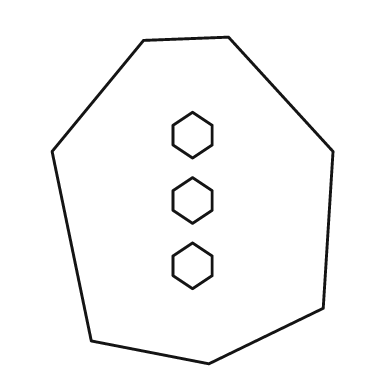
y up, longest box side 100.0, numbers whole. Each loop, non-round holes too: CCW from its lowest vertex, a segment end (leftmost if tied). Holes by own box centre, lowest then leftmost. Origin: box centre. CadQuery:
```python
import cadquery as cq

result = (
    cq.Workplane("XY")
    .moveTo(5.0, -50.0)
    .lineTo(40.0, -33.0)
    .lineTo(43.0, 15.0)
    .lineTo(11.0, 50.0)
    .lineTo(-15.0, 49.0)
    .lineTo(-43.0, 15.0)
    .lineTo(-31.0, -43.0)
    .close()
    .moveTo(0.0, -27.0)
    .lineTo(6.0, -23.0)
    .lineTo(6.0, -17.0)
    .lineTo(0.0, -13.0)
    .lineTo(-6.0, -17.0)
    .lineTo(-6.0, -23.0)
    .close()
    .moveTo(0.0, -7.0)
    .lineTo(6.0, -3.0)
    .lineTo(6.0, 3.0)
    .lineTo(0.0, 7.0)
    .lineTo(-6.0, 3.0)
    .lineTo(-6.0, -3.0)
    .close()
    .moveTo(0.0, 13.0)
    .lineTo(6.0, 17.0)
    .lineTo(6.0, 23.0)
    .lineTo(0.0, 27.0)
    .lineTo(-6.0, 23.0)
    .lineTo(-6.0, 17.0)
    .close()
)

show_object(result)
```